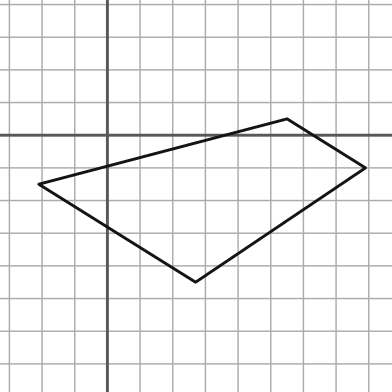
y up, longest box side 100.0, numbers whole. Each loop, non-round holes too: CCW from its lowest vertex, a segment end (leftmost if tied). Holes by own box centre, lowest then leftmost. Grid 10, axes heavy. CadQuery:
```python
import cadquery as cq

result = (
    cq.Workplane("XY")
    .moveTo(27.0, -45.0)
    .lineTo(79.0, -10.0)
    .lineTo(55.0, 5.0)
    .lineTo(-21.0, -15.0)
    .close()
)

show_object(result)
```